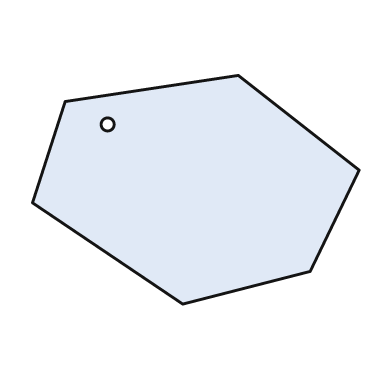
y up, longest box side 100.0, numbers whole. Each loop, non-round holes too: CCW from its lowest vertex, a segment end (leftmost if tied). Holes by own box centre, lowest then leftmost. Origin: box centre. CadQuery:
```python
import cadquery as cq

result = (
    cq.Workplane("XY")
    .moveTo(-4.0, -35.0)
    .lineTo(35.0, -25.0)
    .lineTo(50.0, 6.0)
    .lineTo(13.0, 35.0)
    .lineTo(-40.0, 27.0)
    .lineTo(-50.0, -4.0)
    .close()
    .moveTo(-27.0, 20.0)
    .circle(2.0)
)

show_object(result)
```